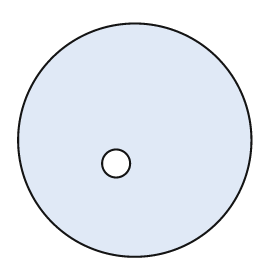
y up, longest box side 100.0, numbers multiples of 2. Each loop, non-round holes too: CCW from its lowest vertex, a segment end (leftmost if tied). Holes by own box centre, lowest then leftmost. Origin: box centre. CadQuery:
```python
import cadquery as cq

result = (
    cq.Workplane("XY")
    .moveTo(0.0, 0.0)
    .circle(50.0)
    .moveTo(-8.0, -10.0)
    .circle(6.0)
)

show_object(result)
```